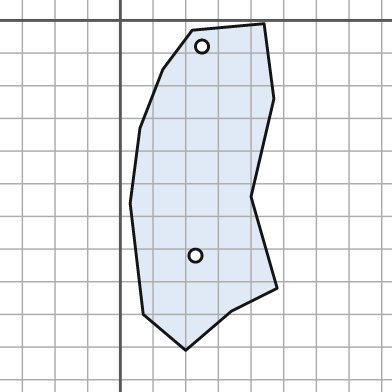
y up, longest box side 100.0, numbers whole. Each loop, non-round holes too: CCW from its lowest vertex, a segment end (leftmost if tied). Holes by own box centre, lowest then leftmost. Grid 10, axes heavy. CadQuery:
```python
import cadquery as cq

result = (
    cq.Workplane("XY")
    .moveTo(20.0, -101.0)
    .lineTo(34.0, -89.0)
    .lineTo(48.0, -82.0)
    .lineTo(40.0, -54.0)
    .lineTo(47.0, -24.0)
    .lineTo(44.0, -1.0)
    .lineTo(22.0, -3.0)
    .lineTo(13.0, -15.0)
    .lineTo(6.0, -33.0)
    .lineTo(3.0, -56.0)
    .lineTo(7.0, -90.0)
    .close()
    .moveTo(23.0, -72.0)
    .circle(2.0)
    .moveTo(25.0, -8.0)
    .circle(2.0)
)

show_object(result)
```